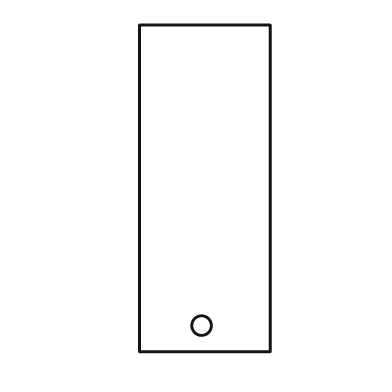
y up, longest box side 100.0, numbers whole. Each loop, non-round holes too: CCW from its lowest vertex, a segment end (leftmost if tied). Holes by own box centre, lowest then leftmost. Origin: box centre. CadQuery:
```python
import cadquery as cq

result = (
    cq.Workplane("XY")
    .moveTo(-20.0, -50.0)
    .lineTo(20.0, -50.0)
    .lineTo(20.0, 50.0)
    .lineTo(-20.0, 50.0)
    .close()
    .moveTo(-1.0, -42.0)
    .circle(3.0)
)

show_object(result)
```